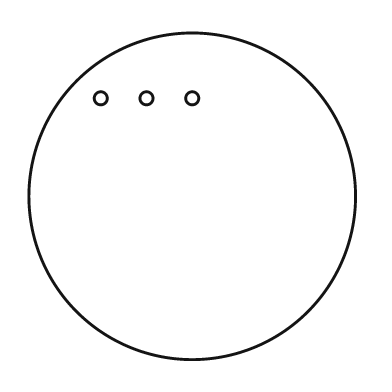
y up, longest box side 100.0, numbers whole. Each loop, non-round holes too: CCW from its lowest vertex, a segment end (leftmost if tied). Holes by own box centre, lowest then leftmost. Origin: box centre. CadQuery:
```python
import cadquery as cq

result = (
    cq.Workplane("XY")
    .moveTo(0.0, 0.0)
    .circle(50.0)
    .moveTo(-28.0, 30.0)
    .circle(2.0)
    .moveTo(-14.0, 30.0)
    .circle(2.0)
    .moveTo(0.0, 30.0)
    .circle(2.0)
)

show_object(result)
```